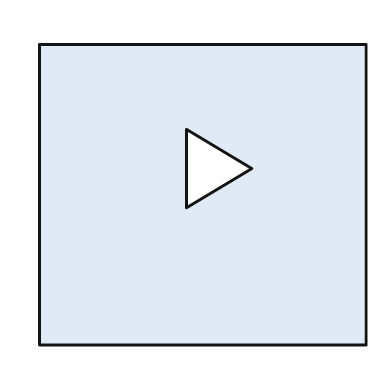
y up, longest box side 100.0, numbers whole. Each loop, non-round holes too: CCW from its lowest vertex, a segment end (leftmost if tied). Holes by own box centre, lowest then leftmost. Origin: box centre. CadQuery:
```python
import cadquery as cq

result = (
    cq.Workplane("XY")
    .moveTo(-50.0, -46.0)
    .lineTo(50.0, -46.0)
    .lineTo(50.0, 46.0)
    .lineTo(-50.0, 46.0)
    .close()
    .moveTo(-5.0, -4.0)
    .lineTo(15.0, 8.0)
    .lineTo(-5.0, 20.0)
    .close()
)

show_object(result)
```